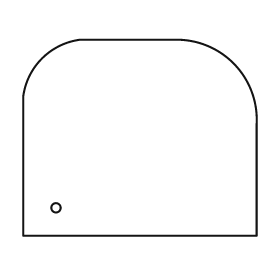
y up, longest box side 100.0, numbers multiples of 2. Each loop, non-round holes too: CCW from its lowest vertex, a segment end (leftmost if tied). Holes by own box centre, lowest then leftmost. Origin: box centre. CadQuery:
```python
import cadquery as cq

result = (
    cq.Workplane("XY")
    .moveTo(-50.0, -42.0)
    .lineTo(50.0, -42.0)
    .lineTo(50.0, 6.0)
    .threePointArc((40.0, 32.0), (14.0, 42.0))
    .lineTo(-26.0, 42.0)
    .threePointArc((-42.0, 34.0), (-50.0, 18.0))
    .close()
    .moveTo(-36.0, -30.0)
    .circle(2.0)
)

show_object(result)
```